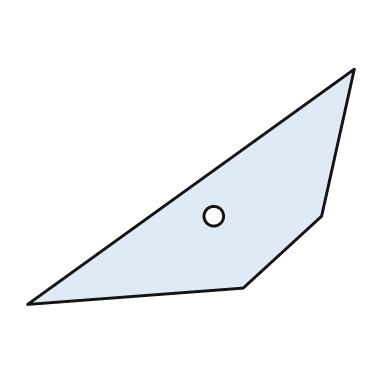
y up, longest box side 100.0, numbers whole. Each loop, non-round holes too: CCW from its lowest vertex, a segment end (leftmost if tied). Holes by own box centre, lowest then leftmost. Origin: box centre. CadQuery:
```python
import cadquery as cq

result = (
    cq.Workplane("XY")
    .moveTo(-50.0, -36.0)
    .lineTo(16.0, -31.0)
    .lineTo(40.0, -9.0)
    .lineTo(50.0, 36.0)
    .close()
    .moveTo(7.0, -9.0)
    .circle(3.0)
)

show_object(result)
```